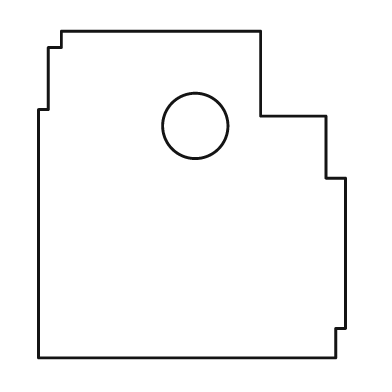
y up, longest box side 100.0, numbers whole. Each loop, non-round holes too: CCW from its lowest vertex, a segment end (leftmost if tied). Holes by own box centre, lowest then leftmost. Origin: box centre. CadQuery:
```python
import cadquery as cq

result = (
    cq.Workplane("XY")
    .moveTo(-47.0, -50.0)
    .lineTo(44.0, -50.0)
    .lineTo(44.0, -41.0)
    .lineTo(47.0, -41.0)
    .lineTo(47.0, 5.0)
    .lineTo(41.0, 5.0)
    .lineTo(41.0, 24.0)
    .lineTo(21.0, 24.0)
    .lineTo(21.0, 50.0)
    .lineTo(-40.0, 50.0)
    .lineTo(-40.0, 45.0)
    .lineTo(-44.0, 45.0)
    .lineTo(-44.0, 26.0)
    .lineTo(-47.0, 26.0)
    .close()
    .moveTo(1.0, 21.0)
    .circle(10.0)
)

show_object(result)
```